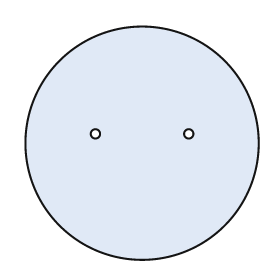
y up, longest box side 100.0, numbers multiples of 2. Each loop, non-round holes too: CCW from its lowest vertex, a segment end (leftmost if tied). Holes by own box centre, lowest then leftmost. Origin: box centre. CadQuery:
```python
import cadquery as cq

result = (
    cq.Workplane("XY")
    .moveTo(0.0, 0.0)
    .circle(50.0)
    .moveTo(-20.0, 4.0)
    .circle(2.0)
    .moveTo(20.0, 4.0)
    .circle(2.0)
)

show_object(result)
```